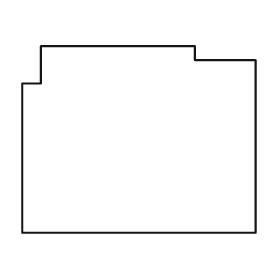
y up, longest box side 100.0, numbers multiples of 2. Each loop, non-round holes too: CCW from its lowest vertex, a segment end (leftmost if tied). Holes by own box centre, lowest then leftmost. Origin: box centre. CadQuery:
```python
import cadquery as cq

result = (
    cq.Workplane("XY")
    .moveTo(-50.0, -40.0)
    .lineTo(50.0, -40.0)
    .lineTo(50.0, 34.0)
    .lineTo(24.0, 34.0)
    .lineTo(24.0, 40.0)
    .lineTo(-42.0, 40.0)
    .lineTo(-42.0, 24.0)
    .lineTo(-50.0, 24.0)
    .close()
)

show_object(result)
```